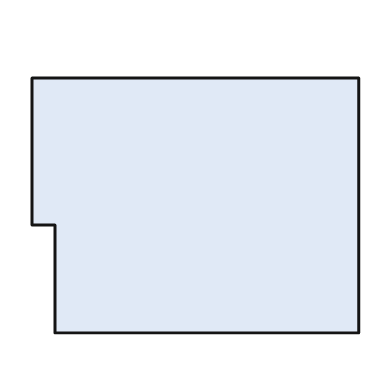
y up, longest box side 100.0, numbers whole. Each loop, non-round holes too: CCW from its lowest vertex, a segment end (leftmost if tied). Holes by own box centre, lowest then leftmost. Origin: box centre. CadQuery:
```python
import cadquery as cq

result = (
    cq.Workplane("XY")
    .moveTo(-43.0, -39.0)
    .lineTo(50.0, -39.0)
    .lineTo(50.0, 39.0)
    .lineTo(-50.0, 39.0)
    .lineTo(-50.0, -6.0)
    .lineTo(-43.0, -6.0)
    .close()
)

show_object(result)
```